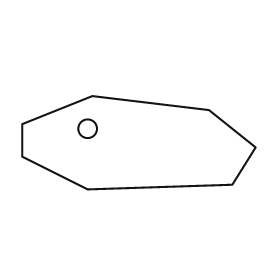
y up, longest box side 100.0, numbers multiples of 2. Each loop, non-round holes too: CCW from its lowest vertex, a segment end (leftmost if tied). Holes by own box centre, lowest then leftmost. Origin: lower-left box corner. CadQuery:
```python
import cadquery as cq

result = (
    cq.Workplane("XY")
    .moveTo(28.0, 0.0)
    .lineTo(90.0, 2.0)
    .lineTo(100.0, 18.0)
    .lineTo(80.0, 34.0)
    .lineTo(30.0, 40.0)
    .lineTo(0.0, 28.0)
    .lineTo(0.0, 14.0)
    .close()
    .moveTo(28.0, 26.0)
    .circle(4.0)
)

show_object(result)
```